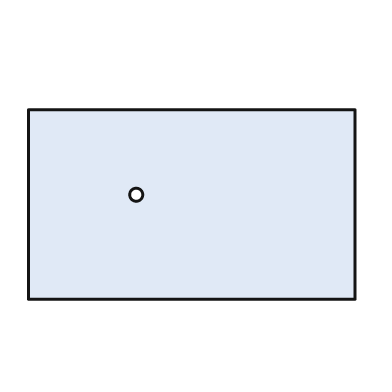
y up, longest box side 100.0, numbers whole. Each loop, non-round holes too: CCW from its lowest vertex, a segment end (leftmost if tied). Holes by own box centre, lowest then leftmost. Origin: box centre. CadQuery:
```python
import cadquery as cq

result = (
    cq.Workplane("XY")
    .moveTo(-50.0, -29.0)
    .lineTo(50.0, -29.0)
    .lineTo(50.0, 29.0)
    .lineTo(-50.0, 29.0)
    .close()
    .moveTo(-17.0, 3.0)
    .circle(2.0)
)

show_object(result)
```